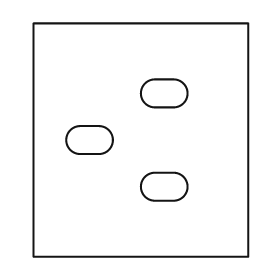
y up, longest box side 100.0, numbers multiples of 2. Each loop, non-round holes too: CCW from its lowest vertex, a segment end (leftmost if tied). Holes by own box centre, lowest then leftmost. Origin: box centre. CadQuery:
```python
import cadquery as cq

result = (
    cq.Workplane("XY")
    .moveTo(-46.0, -50.0)
    .lineTo(46.0, -50.0)
    .lineTo(46.0, 50.0)
    .lineTo(-46.0, 50.0)
    .close()
    .moveTo(6.0, -26.0)
    .lineTo(14.0, -26.0)
    .threePointArc((20.0, -20.0), (14.0, -14.0))
    .lineTo(6.0, -14.0)
    .threePointArc((0.0, -20.0), (6.0, -26.0))
    .close()
    .moveTo(-26.0, -6.0)
    .lineTo(-18.0, -6.0)
    .threePointArc((-12.0, 0.0), (-18.0, 6.0))
    .lineTo(-26.0, 6.0)
    .threePointArc((-32.0, 0.0), (-26.0, -6.0))
    .close()
    .moveTo(6.0, 14.0)
    .lineTo(14.0, 14.0)
    .threePointArc((20.0, 20.0), (14.0, 26.0))
    .lineTo(6.0, 26.0)
    .threePointArc((0.0, 20.0), (6.0, 14.0))
    .close()
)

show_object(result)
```